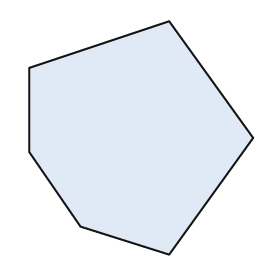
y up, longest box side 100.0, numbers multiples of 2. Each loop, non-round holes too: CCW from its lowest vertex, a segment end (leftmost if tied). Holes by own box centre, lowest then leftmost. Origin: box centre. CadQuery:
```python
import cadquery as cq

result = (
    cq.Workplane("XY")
    .moveTo(12.0, -50.0)
    .lineTo(48.0, 0.0)
    .lineTo(12.0, 50.0)
    .lineTo(-48.0, 30.0)
    .lineTo(-48.0, -6.0)
    .lineTo(-26.0, -38.0)
    .close()
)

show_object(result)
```